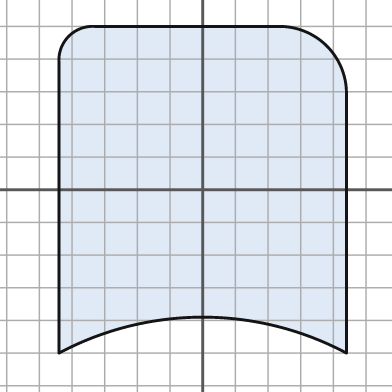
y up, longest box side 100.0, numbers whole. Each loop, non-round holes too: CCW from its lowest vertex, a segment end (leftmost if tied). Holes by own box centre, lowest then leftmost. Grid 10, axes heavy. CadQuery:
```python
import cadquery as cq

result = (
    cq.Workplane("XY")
    .moveTo(-44.0, -50.0)
    .threePointArc((0.0, -39.0), (44.0, -50.0))
    .lineTo(44.0, 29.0)
    .threePointArc((38.0, 44.0), (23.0, 50.0))
    .lineTo(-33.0, 50.0)
    .threePointArc((-41.0, 47.0), (-44.0, 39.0))
    .close()
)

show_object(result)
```